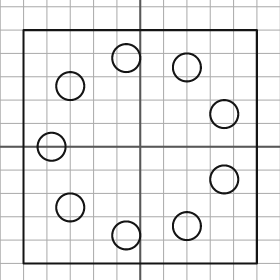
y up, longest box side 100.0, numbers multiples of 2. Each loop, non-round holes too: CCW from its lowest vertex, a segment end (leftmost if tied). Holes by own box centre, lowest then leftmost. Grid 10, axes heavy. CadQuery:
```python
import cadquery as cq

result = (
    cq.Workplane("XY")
    .moveTo(-50.0, -50.0)
    .lineTo(50.0, -50.0)
    .lineTo(50.0, 50.0)
    .lineTo(-50.0, 50.0)
    .close()
    .moveTo(-6.0, -38.0)
    .circle(6.0)
    .moveTo(20.0, -34.0)
    .circle(6.0)
    .moveTo(-30.0, -26.0)
    .circle(6.0)
    .moveTo(36.0, -14.0)
    .circle(6.0)
    .moveTo(-38.0, 0.0)
    .circle(6.0)
    .moveTo(36.0, 14.0)
    .circle(6.0)
    .moveTo(-30.0, 26.0)
    .circle(6.0)
    .moveTo(20.0, 34.0)
    .circle(6.0)
    .moveTo(-6.0, 38.0)
    .circle(6.0)
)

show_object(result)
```